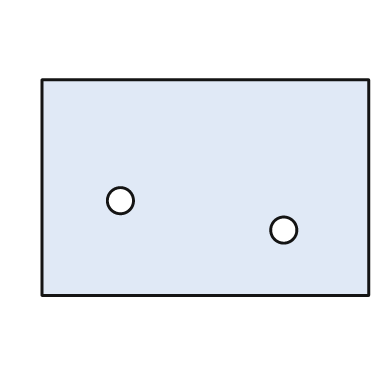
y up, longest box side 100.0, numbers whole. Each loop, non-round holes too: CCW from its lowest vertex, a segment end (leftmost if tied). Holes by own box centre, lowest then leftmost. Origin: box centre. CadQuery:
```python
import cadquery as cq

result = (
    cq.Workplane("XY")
    .moveTo(-50.0, -33.0)
    .lineTo(50.0, -33.0)
    .lineTo(50.0, 33.0)
    .lineTo(-50.0, 33.0)
    .close()
    .moveTo(24.0, -13.0)
    .circle(4.0)
    .moveTo(-26.0, -4.0)
    .circle(4.0)
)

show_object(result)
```